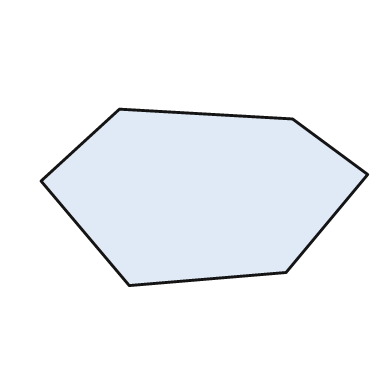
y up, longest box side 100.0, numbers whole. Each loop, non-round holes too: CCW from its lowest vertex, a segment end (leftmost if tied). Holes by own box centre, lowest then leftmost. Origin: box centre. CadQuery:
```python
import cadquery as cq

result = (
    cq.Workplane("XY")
    .moveTo(-23.0, -27.0)
    .lineTo(25.0, -23.0)
    .lineTo(50.0, 7.0)
    .lineTo(27.0, 24.0)
    .lineTo(-26.0, 27.0)
    .lineTo(-50.0, 5.0)
    .close()
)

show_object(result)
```